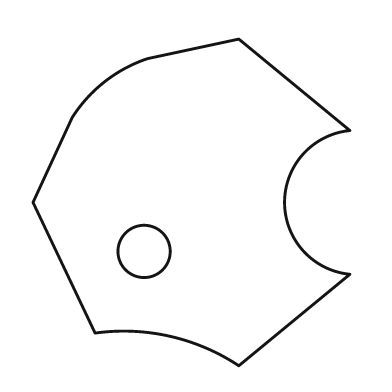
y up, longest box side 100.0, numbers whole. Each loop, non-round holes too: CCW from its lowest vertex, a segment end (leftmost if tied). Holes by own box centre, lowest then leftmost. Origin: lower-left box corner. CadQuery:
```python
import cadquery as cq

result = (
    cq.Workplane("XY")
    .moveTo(63.0, 0.0)
    .lineTo(97.0, 28.0)
    .threePointArc((77.0, 50.0), (97.0, 72.0))
    .lineTo(63.0, 100.0)
    .lineTo(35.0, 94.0)
    .threePointArc((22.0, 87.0), (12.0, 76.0))
    .lineTo(0.0, 50.0)
    .lineTo(19.0, 10.0)
    .threePointArc((42.0, 9.0), (63.0, 0.0))
    .close()
    .moveTo(34.0, 35.0)
    .circle(8.0)
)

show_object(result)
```